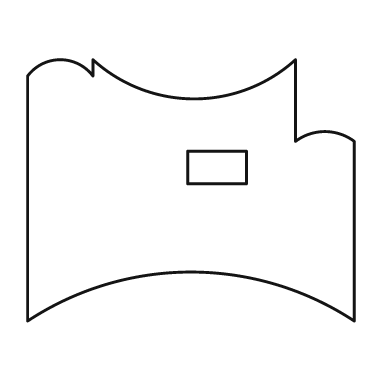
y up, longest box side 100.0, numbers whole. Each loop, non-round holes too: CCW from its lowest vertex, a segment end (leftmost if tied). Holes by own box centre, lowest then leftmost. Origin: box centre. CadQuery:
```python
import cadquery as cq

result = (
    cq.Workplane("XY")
    .moveTo(-50.0, -40.0)
    .threePointArc((0.0, -25.0), (50.0, -40.0))
    .lineTo(50.0, 15.0)
    .threePointArc((41.0, 18.0), (32.0, 15.0))
    .lineTo(32.0, 40.0)
    .threePointArc((1.0, 28.0), (-30.0, 40.0))
    .lineTo(-30.0, 35.0)
    .threePointArc((-40.0, 40.0), (-50.0, 35.0))
    .close()
    .moveTo(-1.0, 2.0)
    .lineTo(17.0, 2.0)
    .lineTo(17.0, 12.0)
    .lineTo(-1.0, 12.0)
    .close()
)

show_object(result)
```